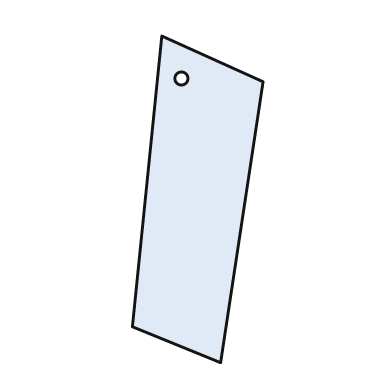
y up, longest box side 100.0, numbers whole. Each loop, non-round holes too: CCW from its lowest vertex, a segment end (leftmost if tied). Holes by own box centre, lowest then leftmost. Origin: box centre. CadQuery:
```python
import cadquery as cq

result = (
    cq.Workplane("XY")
    .moveTo(7.0, -50.0)
    .lineTo(20.0, 36.0)
    .lineTo(-11.0, 50.0)
    .lineTo(-20.0, -39.0)
    .close()
    .moveTo(-5.0, 37.0)
    .circle(2.0)
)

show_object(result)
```